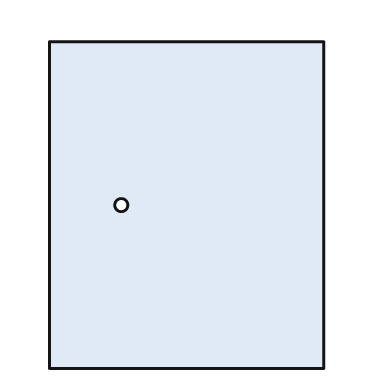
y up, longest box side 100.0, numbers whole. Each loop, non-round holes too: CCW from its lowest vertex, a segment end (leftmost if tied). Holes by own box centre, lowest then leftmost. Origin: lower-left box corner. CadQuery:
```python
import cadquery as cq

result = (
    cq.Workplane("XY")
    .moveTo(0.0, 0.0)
    .lineTo(84.0, 0.0)
    .lineTo(84.0, 100.0)
    .lineTo(0.0, 100.0)
    .close()
    .moveTo(22.0, 50.0)
    .circle(2.0)
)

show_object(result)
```